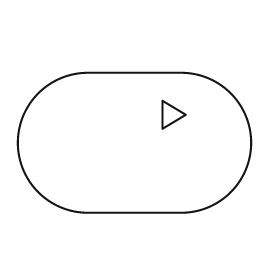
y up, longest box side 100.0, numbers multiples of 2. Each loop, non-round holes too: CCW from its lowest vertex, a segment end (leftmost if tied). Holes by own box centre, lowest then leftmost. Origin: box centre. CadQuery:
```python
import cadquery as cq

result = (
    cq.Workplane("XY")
    .moveTo(-20.0, -30.0)
    .lineTo(20.0, -30.0)
    .threePointArc((50.0, 0.0), (20.0, 30.0))
    .lineTo(-20.0, 30.0)
    .threePointArc((-50.0, 0.0), (-20.0, -30.0))
    .close()
    .moveTo(12.0, 6.0)
    .lineTo(22.0, 12.0)
    .lineTo(12.0, 18.0)
    .close()
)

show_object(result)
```